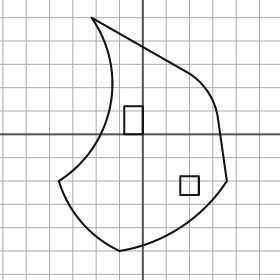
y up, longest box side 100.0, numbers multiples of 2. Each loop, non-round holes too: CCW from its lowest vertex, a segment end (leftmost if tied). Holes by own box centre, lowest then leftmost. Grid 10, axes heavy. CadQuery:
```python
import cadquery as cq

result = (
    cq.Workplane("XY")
    .moveTo(-10.0, -50.0)
    .threePointArc((16.0, -40.0), (36.0, -20.0))
    .lineTo(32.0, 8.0)
    .threePointArc((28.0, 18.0), (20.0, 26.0))
    .lineTo(-22.0, 50.0)
    .threePointArc((-14.0, 12.0), (-36.0, -20.0))
    .threePointArc((-26.0, -38.0), (-10.0, -50.0))
    .close()
    .moveTo(16.0, -26.0)
    .lineTo(24.0, -26.0)
    .lineTo(24.0, -18.0)
    .lineTo(16.0, -18.0)
    .close()
    .moveTo(-8.0, 0.0)
    .lineTo(0.0, 0.0)
    .lineTo(0.0, 12.0)
    .lineTo(-8.0, 12.0)
    .close()
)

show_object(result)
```